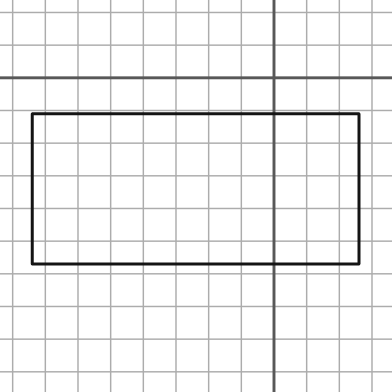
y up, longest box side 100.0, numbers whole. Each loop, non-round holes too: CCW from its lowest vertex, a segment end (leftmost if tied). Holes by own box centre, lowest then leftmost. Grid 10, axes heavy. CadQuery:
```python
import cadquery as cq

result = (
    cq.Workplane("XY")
    .moveTo(-74.0, -57.0)
    .lineTo(26.0, -57.0)
    .lineTo(26.0, -11.0)
    .lineTo(-74.0, -11.0)
    .close()
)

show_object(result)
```